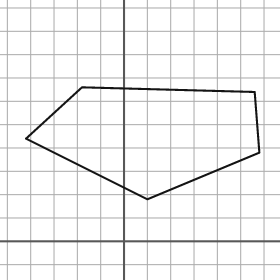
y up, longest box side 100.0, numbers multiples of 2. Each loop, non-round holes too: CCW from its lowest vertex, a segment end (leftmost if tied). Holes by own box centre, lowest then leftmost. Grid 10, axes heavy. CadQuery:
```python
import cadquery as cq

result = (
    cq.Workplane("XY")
    .moveTo(10.0, 18.0)
    .lineTo(58.0, 38.0)
    .lineTo(56.0, 64.0)
    .lineTo(-18.0, 66.0)
    .lineTo(-42.0, 44.0)
    .close()
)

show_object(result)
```